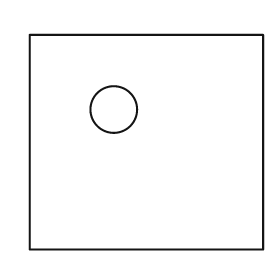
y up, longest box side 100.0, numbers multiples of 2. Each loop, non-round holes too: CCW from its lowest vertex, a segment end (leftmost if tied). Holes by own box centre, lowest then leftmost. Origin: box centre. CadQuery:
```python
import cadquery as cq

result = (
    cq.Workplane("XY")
    .moveTo(-50.0, -46.0)
    .lineTo(50.0, -46.0)
    .lineTo(50.0, 46.0)
    .lineTo(-50.0, 46.0)
    .close()
    .moveTo(-14.0, 14.0)
    .circle(10.0)
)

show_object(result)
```